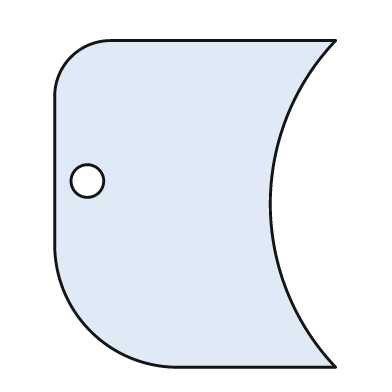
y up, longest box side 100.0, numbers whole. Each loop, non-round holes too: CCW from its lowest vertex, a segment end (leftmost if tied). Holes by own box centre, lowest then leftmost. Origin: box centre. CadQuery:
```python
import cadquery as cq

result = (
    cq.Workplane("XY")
    .moveTo(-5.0, -50.0)
    .lineTo(43.0, -50.0)
    .threePointArc((23.0, 0.0), (43.0, 50.0))
    .lineTo(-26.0, 50.0)
    .threePointArc((-38.0, 45.0), (-43.0, 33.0))
    .lineTo(-43.0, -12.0)
    .threePointArc((-32.0, -39.0), (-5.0, -50.0))
    .close()
    .moveTo(-33.0, 7.0)
    .circle(5.0)
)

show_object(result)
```